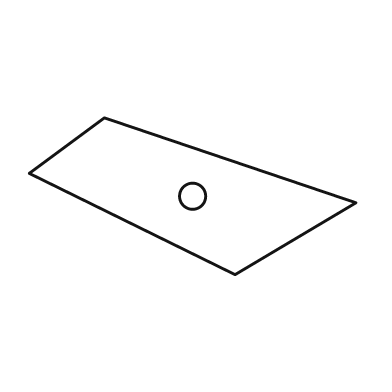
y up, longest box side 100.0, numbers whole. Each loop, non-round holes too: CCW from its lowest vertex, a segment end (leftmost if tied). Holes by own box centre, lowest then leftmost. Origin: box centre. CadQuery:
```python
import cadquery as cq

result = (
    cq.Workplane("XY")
    .moveTo(13.0, -24.0)
    .lineTo(50.0, -2.0)
    .lineTo(-27.0, 24.0)
    .lineTo(-50.0, 7.0)
    .close()
    .moveTo(0.0, 0.0)
    .circle(4.0)
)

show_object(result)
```